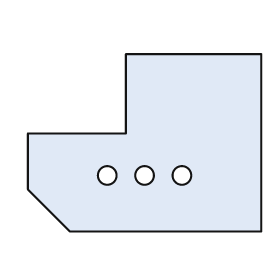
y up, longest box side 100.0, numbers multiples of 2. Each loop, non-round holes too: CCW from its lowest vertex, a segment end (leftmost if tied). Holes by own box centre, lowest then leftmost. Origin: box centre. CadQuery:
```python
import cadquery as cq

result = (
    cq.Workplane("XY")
    .moveTo(-32.0, -38.0)
    .lineTo(50.0, -38.0)
    .lineTo(50.0, 38.0)
    .lineTo(-8.0, 38.0)
    .lineTo(-8.0, 4.0)
    .lineTo(-50.0, 4.0)
    .lineTo(-50.0, -20.0)
    .close()
    .moveTo(-16.0, -14.0)
    .circle(4.0)
    .moveTo(0.0, -14.0)
    .circle(4.0)
    .moveTo(16.0, -14.0)
    .circle(4.0)
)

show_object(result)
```